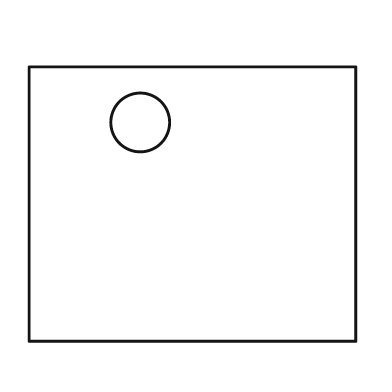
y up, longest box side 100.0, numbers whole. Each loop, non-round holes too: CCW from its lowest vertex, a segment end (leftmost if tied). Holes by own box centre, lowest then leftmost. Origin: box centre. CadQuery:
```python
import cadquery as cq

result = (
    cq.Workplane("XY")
    .moveTo(-50.0, -42.0)
    .lineTo(50.0, -42.0)
    .lineTo(50.0, 42.0)
    .lineTo(-50.0, 42.0)
    .close()
    .moveTo(-16.0, 25.0)
    .circle(9.0)
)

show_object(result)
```